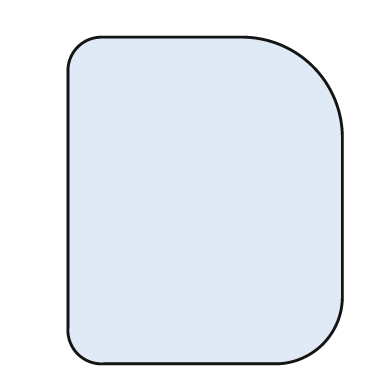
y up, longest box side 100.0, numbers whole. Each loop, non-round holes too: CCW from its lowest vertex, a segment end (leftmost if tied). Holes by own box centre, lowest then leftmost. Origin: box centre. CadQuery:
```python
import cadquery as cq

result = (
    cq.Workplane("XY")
    .moveTo(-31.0, -50.0)
    .lineTo(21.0, -50.0)
    .threePointArc((36.0, -44.0), (42.0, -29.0))
    .lineTo(42.0, 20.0)
    .threePointArc((33.0, 41.0), (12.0, 50.0))
    .lineTo(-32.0, 50.0)
    .threePointArc((-39.0, 47.0), (-42.0, 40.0))
    .lineTo(-42.0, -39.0)
    .threePointArc((-39.0, -47.0), (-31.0, -50.0))
    .close()
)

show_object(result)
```